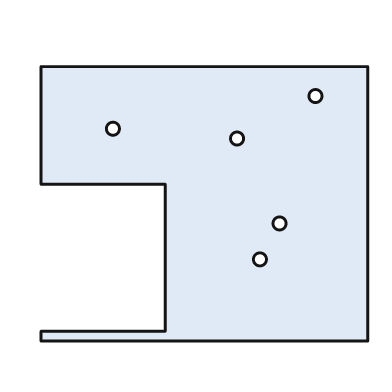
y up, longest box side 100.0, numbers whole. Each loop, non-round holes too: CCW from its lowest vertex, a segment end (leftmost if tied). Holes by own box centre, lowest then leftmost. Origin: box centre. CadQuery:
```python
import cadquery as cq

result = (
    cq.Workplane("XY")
    .moveTo(-50.0, -42.0)
    .lineTo(50.0, -42.0)
    .lineTo(50.0, 42.0)
    .lineTo(-50.0, 42.0)
    .lineTo(-50.0, 6.0)
    .lineTo(-12.0, 6.0)
    .lineTo(-12.0, -39.0)
    .lineTo(-50.0, -39.0)
    .close()
    .moveTo(17.0, -17.0)
    .circle(2.0)
    .moveTo(23.0, -6.0)
    .circle(2.0)
    .moveTo(10.0, 20.0)
    .circle(2.0)
    .moveTo(-28.0, 23.0)
    .circle(2.0)
    .moveTo(34.0, 33.0)
    .circle(2.0)
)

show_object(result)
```